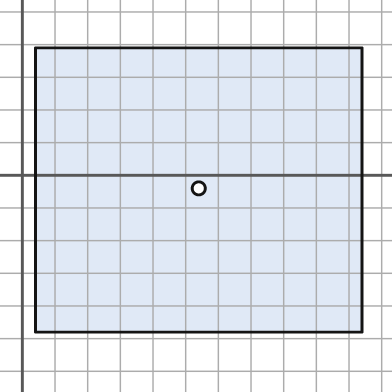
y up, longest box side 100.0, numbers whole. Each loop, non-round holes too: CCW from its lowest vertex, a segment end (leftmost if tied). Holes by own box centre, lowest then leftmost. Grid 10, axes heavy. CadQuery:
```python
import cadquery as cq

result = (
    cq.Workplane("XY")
    .moveTo(4.0, -48.0)
    .lineTo(104.0, -48.0)
    .lineTo(104.0, 39.0)
    .lineTo(4.0, 39.0)
    .close()
    .moveTo(54.0, -4.0)
    .circle(2.0)
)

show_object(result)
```